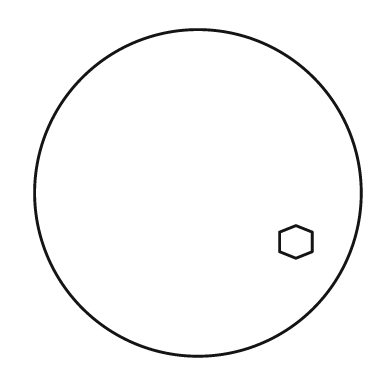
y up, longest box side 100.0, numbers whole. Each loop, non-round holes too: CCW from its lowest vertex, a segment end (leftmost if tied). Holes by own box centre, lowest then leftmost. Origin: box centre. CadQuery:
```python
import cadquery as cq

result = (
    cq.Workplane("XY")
    .moveTo(0.0, 0.0)
    .circle(50.0)
    .moveTo(30.0, -20.0)
    .lineTo(35.0, -18.0)
    .lineTo(35.0, -12.0)
    .lineTo(30.0, -10.0)
    .lineTo(25.0, -12.0)
    .lineTo(25.0, -18.0)
    .close()
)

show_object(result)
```